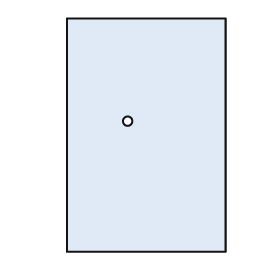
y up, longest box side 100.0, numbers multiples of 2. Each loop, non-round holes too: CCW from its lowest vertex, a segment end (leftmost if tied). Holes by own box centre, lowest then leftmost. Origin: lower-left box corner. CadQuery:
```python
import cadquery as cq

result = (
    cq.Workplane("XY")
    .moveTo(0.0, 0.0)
    .lineTo(68.0, 0.0)
    .lineTo(68.0, 100.0)
    .lineTo(0.0, 100.0)
    .close()
    .moveTo(26.0, 56.0)
    .circle(2.0)
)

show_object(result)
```